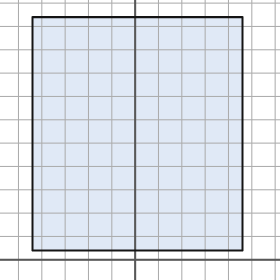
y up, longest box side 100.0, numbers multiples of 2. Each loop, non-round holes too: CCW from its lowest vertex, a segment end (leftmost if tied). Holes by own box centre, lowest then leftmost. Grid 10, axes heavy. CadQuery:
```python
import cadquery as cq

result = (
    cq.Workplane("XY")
    .moveTo(-44.0, 4.0)
    .lineTo(46.0, 4.0)
    .lineTo(46.0, 104.0)
    .lineTo(-44.0, 104.0)
    .close()
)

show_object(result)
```